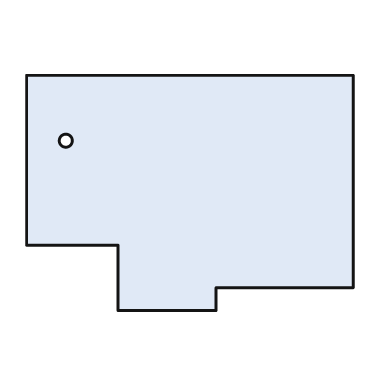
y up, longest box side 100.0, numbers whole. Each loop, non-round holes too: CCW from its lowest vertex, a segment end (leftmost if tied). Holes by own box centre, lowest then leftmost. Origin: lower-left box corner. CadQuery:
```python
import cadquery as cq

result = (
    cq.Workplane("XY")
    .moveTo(28.0, 0.0)
    .lineTo(58.0, 0.0)
    .lineTo(58.0, 7.0)
    .lineTo(100.0, 7.0)
    .lineTo(100.0, 72.0)
    .lineTo(0.0, 72.0)
    .lineTo(0.0, 20.0)
    .lineTo(28.0, 20.0)
    .close()
    .moveTo(12.0, 52.0)
    .circle(2.0)
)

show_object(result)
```